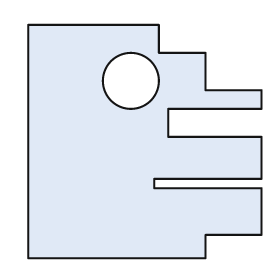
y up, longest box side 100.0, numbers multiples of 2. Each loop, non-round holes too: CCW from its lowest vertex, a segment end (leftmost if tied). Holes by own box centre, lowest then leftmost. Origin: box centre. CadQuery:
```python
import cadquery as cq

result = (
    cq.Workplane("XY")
    .moveTo(-50.0, -50.0)
    .lineTo(26.0, -50.0)
    .lineTo(26.0, -40.0)
    .lineTo(50.0, -40.0)
    .lineTo(50.0, -20.0)
    .lineTo(4.0, -20.0)
    .lineTo(4.0, -16.0)
    .lineTo(50.0, -16.0)
    .lineTo(50.0, 2.0)
    .lineTo(10.0, 2.0)
    .lineTo(10.0, 14.0)
    .lineTo(50.0, 14.0)
    .lineTo(50.0, 22.0)
    .lineTo(26.0, 22.0)
    .lineTo(26.0, 38.0)
    .lineTo(6.0, 38.0)
    .lineTo(6.0, 50.0)
    .lineTo(-50.0, 50.0)
    .close()
    .moveTo(-6.0, 26.0)
    .circle(12.0)
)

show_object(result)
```